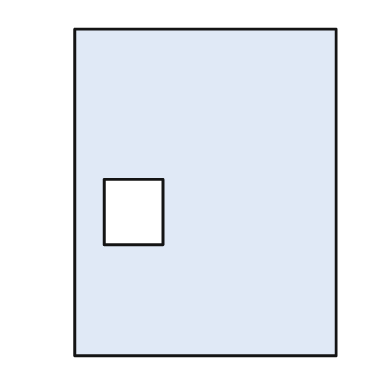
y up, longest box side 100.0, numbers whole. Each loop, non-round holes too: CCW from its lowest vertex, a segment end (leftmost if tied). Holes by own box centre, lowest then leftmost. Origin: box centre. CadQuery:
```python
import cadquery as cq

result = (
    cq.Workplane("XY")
    .moveTo(-40.0, -50.0)
    .lineTo(40.0, -50.0)
    .lineTo(40.0, 50.0)
    .lineTo(-40.0, 50.0)
    .close()
    .moveTo(-31.0, -16.0)
    .lineTo(-13.0, -16.0)
    .lineTo(-13.0, 4.0)
    .lineTo(-31.0, 4.0)
    .close()
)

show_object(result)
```